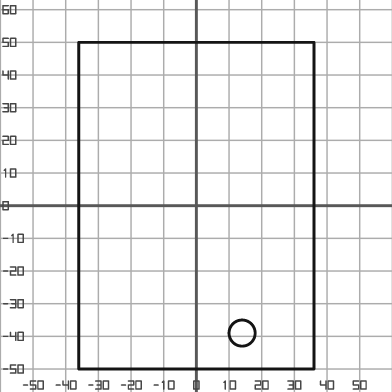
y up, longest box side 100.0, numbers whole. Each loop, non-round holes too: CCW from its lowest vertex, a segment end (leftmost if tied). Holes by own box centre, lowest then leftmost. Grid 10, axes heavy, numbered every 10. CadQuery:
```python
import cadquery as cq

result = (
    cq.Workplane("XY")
    .moveTo(-36.0, -50.0)
    .lineTo(36.0, -50.0)
    .lineTo(36.0, 50.0)
    .lineTo(-36.0, 50.0)
    .close()
    .moveTo(14.0, -39.0)
    .circle(4.0)
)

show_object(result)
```